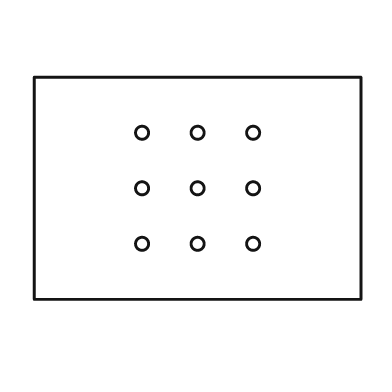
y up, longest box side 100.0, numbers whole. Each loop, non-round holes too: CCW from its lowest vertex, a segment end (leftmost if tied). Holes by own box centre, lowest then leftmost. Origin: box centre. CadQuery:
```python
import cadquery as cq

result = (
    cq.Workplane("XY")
    .moveTo(-50.0, -34.0)
    .lineTo(50.0, -34.0)
    .lineTo(50.0, 34.0)
    .lineTo(-50.0, 34.0)
    .close()
    .moveTo(-17.0, -17.0)
    .circle(2.0)
    .moveTo(0.0, -17.0)
    .circle(2.0)
    .moveTo(17.0, -17.0)
    .circle(2.0)
    .moveTo(-17.0, 0.0)
    .circle(2.0)
    .moveTo(0.0, 0.0)
    .circle(2.0)
    .moveTo(17.0, 0.0)
    .circle(2.0)
    .moveTo(-17.0, 17.0)
    .circle(2.0)
    .moveTo(0.0, 17.0)
    .circle(2.0)
    .moveTo(17.0, 17.0)
    .circle(2.0)
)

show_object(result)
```